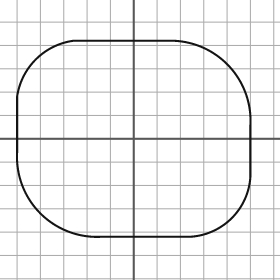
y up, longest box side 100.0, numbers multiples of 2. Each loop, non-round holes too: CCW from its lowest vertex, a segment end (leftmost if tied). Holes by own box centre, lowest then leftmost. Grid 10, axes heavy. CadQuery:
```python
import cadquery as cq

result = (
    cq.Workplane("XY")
    .moveTo(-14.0, -42.0)
    .lineTo(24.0, -42.0)
    .threePointArc((42.0, -34.0), (50.0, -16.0))
    .lineTo(50.0, 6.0)
    .threePointArc((40.0, 32.0), (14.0, 42.0))
    .lineTo(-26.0, 42.0)
    .threePointArc((-42.0, 34.0), (-50.0, 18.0))
    .lineTo(-50.0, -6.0)
    .threePointArc((-40.0, -32.0), (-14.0, -42.0))
    .close()
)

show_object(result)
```